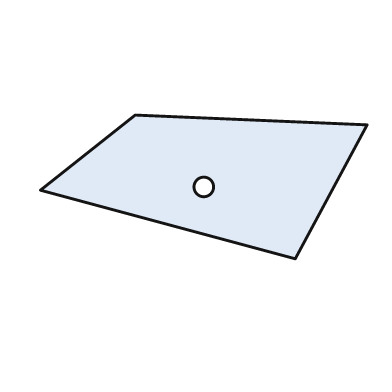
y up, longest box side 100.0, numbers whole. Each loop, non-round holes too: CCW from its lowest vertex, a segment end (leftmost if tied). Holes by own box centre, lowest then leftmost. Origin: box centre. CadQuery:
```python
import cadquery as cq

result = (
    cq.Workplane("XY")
    .moveTo(28.0, -22.0)
    .lineTo(50.0, 19.0)
    .lineTo(-21.0, 22.0)
    .lineTo(-50.0, -1.0)
    .close()
    .moveTo(0.0, 0.0)
    .circle(3.0)
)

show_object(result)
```